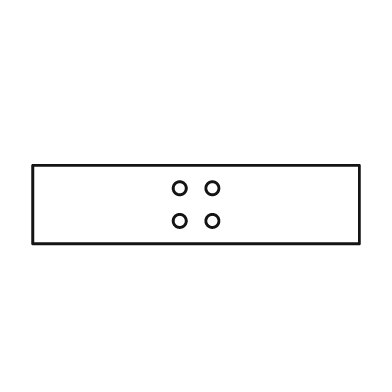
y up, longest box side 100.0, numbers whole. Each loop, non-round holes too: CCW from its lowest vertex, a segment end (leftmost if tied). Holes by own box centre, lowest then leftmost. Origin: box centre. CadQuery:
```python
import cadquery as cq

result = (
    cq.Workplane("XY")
    .moveTo(-50.0, -12.0)
    .lineTo(50.0, -12.0)
    .lineTo(50.0, 12.0)
    .lineTo(-50.0, 12.0)
    .close()
    .moveTo(-5.0, -5.0)
    .circle(2.0)
    .moveTo(5.0, -5.0)
    .circle(2.0)
    .moveTo(-5.0, 5.0)
    .circle(2.0)
    .moveTo(5.0, 5.0)
    .circle(2.0)
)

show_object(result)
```